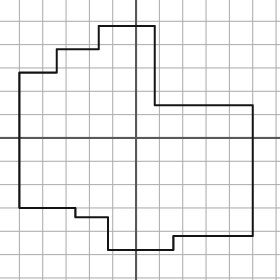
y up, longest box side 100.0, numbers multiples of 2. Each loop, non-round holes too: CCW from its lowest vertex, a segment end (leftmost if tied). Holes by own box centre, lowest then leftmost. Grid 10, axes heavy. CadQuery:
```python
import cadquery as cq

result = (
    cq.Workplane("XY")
    .moveTo(-12.0, -48.0)
    .lineTo(16.0, -48.0)
    .lineTo(16.0, -42.0)
    .lineTo(50.0, -42.0)
    .lineTo(50.0, 14.0)
    .lineTo(8.0, 14.0)
    .lineTo(8.0, 48.0)
    .lineTo(-16.0, 48.0)
    .lineTo(-16.0, 38.0)
    .lineTo(-34.0, 38.0)
    .lineTo(-34.0, 28.0)
    .lineTo(-50.0, 28.0)
    .lineTo(-50.0, -30.0)
    .lineTo(-26.0, -30.0)
    .lineTo(-26.0, -34.0)
    .lineTo(-12.0, -34.0)
    .close()
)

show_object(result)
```